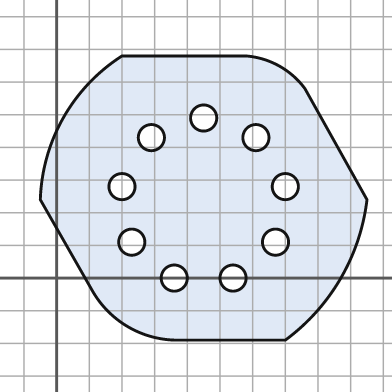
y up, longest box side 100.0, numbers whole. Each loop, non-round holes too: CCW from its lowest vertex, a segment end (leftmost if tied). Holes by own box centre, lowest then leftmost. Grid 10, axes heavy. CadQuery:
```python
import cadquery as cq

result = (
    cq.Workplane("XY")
    .moveTo(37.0, -19.0)
    .lineTo(70.0, -19.0)
    .threePointArc((87.0, 0.0), (95.0, 24.0))
    .lineTo(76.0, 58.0)
    .threePointArc((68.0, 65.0), (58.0, 68.0))
    .lineTo(20.0, 68.0)
    .threePointArc((2.0, 49.0), (-5.0, 24.0))
    .lineTo(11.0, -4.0)
    .threePointArc((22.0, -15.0), (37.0, -19.0))
    .close()
    .moveTo(36.0, 0.0)
    .circle(4.0)
    .moveTo(54.0, 0.0)
    .circle(4.0)
    .moveTo(23.0, 11.0)
    .circle(4.0)
    .moveTo(67.0, 11.0)
    .circle(4.0)
    .moveTo(20.0, 28.0)
    .circle(4.0)
    .moveTo(70.0, 28.0)
    .circle(4.0)
    .moveTo(29.0, 43.0)
    .circle(4.0)
    .moveTo(61.0, 43.0)
    .circle(4.0)
    .moveTo(45.0, 49.0)
    .circle(4.0)
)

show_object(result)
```